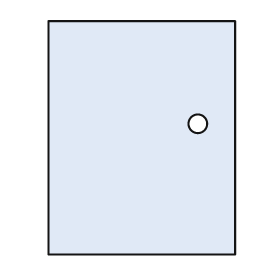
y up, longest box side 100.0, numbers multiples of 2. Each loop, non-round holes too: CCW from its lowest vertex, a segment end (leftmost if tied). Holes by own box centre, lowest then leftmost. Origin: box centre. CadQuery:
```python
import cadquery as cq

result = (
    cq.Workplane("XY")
    .moveTo(-40.0, -50.0)
    .lineTo(40.0, -50.0)
    .lineTo(40.0, 50.0)
    .lineTo(-40.0, 50.0)
    .close()
    .moveTo(24.0, 6.0)
    .circle(4.0)
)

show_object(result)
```